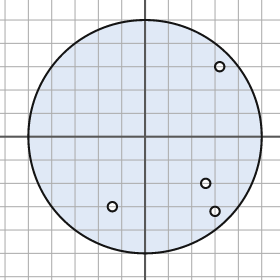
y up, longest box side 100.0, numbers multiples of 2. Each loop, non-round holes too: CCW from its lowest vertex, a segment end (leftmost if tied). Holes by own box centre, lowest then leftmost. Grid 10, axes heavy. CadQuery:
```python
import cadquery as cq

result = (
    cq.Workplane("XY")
    .moveTo(0.0, 0.0)
    .circle(50.0)
    .moveTo(30.0, -32.0)
    .circle(2.0)
    .moveTo(-14.0, -30.0)
    .circle(2.0)
    .moveTo(26.0, -20.0)
    .circle(2.0)
    .moveTo(32.0, 30.0)
    .circle(2.0)
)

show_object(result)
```